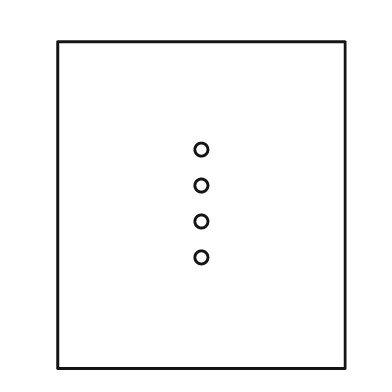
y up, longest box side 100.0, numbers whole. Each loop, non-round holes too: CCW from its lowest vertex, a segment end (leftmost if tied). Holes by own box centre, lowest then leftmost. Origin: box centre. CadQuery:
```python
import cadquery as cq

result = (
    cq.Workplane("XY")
    .moveTo(-44.0, -50.0)
    .lineTo(44.0, -50.0)
    .lineTo(44.0, 50.0)
    .lineTo(-44.0, 50.0)
    .close()
    .moveTo(0.0, -16.0)
    .circle(2.0)
    .moveTo(0.0, -5.0)
    .circle(2.0)
    .moveTo(0.0, 6.0)
    .circle(2.0)
    .moveTo(0.0, 17.0)
    .circle(2.0)
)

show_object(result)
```